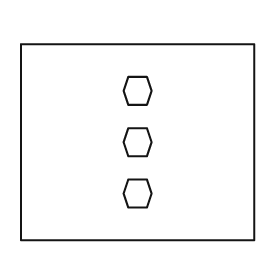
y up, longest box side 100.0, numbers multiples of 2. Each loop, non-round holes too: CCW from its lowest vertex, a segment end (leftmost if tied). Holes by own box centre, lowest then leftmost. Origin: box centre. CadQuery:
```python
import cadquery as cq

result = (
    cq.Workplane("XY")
    .moveTo(-50.0, -42.0)
    .lineTo(50.0, -42.0)
    .lineTo(50.0, 42.0)
    .lineTo(-50.0, 42.0)
    .close()
    .moveTo(-4.0, -28.0)
    .lineTo(4.0, -28.0)
    .lineTo(6.0, -22.0)
    .lineTo(4.0, -16.0)
    .lineTo(-4.0, -16.0)
    .lineTo(-6.0, -22.0)
    .close()
    .moveTo(-4.0, -6.0)
    .lineTo(4.0, -6.0)
    .lineTo(6.0, 0.0)
    .lineTo(4.0, 6.0)
    .lineTo(-4.0, 6.0)
    .lineTo(-6.0, 0.0)
    .close()
    .moveTo(-4.0, 16.0)
    .lineTo(4.0, 16.0)
    .lineTo(6.0, 22.0)
    .lineTo(4.0, 28.0)
    .lineTo(-4.0, 28.0)
    .lineTo(-6.0, 22.0)
    .close()
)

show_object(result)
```